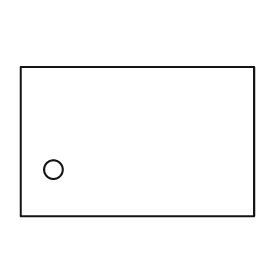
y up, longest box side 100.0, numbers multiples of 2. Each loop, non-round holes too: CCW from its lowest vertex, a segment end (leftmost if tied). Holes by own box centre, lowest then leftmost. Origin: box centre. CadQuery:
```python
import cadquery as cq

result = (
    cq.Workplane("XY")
    .moveTo(-50.0, -32.0)
    .lineTo(50.0, -32.0)
    .lineTo(50.0, 32.0)
    .lineTo(-50.0, 32.0)
    .close()
    .moveTo(-36.0, -12.0)
    .circle(4.0)
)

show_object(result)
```